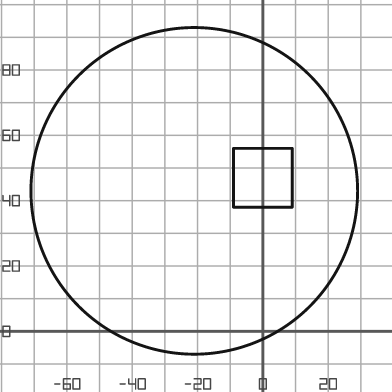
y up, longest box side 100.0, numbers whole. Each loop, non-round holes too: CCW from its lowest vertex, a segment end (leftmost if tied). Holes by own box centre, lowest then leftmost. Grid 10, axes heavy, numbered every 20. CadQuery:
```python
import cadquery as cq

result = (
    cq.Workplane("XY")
    .moveTo(-21.0, 43.0)
    .circle(50.0)
    .moveTo(-9.0, 38.0)
    .lineTo(9.0, 38.0)
    .lineTo(9.0, 56.0)
    .lineTo(-9.0, 56.0)
    .close()
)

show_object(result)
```